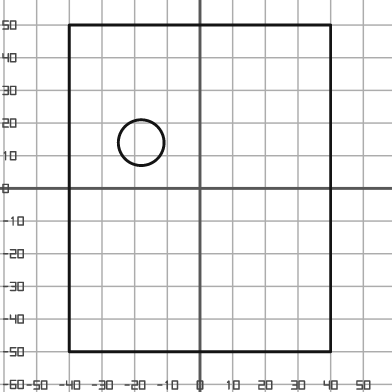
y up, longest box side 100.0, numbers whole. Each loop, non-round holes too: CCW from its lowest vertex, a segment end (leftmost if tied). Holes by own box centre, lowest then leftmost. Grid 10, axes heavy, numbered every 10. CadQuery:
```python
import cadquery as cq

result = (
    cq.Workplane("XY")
    .moveTo(-40.0, -50.0)
    .lineTo(40.0, -50.0)
    .lineTo(40.0, 50.0)
    .lineTo(-40.0, 50.0)
    .close()
    .moveTo(-18.0, 14.0)
    .circle(7.0)
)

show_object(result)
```